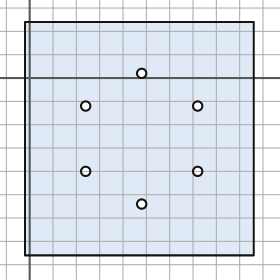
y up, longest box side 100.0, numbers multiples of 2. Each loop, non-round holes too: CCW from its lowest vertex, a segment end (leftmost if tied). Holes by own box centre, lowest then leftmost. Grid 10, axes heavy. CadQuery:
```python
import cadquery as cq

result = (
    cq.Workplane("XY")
    .moveTo(-2.0, -76.0)
    .lineTo(96.0, -76.0)
    .lineTo(96.0, 24.0)
    .lineTo(-2.0, 24.0)
    .close()
    .moveTo(48.0, -54.0)
    .circle(2.0)
    .moveTo(24.0, -40.0)
    .circle(2.0)
    .moveTo(72.0, -40.0)
    .circle(2.0)
    .moveTo(24.0, -12.0)
    .circle(2.0)
    .moveTo(72.0, -12.0)
    .circle(2.0)
    .moveTo(48.0, 2.0)
    .circle(2.0)
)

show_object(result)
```